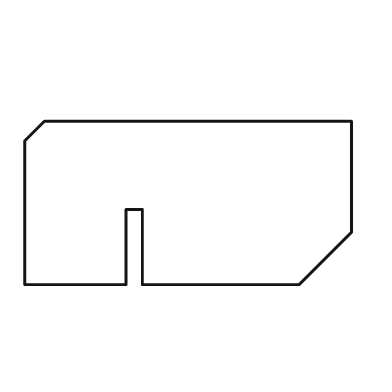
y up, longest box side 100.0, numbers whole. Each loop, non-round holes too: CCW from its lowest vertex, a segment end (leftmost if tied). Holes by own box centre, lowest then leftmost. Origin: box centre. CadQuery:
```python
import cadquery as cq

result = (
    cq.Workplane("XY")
    .moveTo(-50.0, -25.0)
    .lineTo(-19.0, -25.0)
    .lineTo(-19.0, -2.0)
    .lineTo(-14.0, -2.0)
    .lineTo(-14.0, -25.0)
    .lineTo(34.0, -25.0)
    .lineTo(50.0, -9.0)
    .lineTo(50.0, 25.0)
    .lineTo(-44.0, 25.0)
    .lineTo(-50.0, 19.0)
    .close()
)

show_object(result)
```